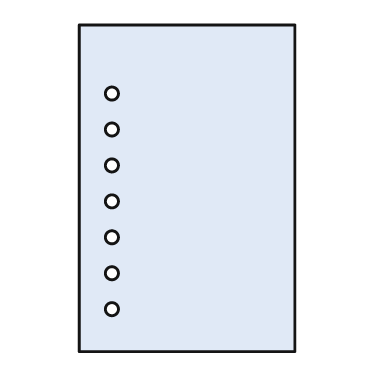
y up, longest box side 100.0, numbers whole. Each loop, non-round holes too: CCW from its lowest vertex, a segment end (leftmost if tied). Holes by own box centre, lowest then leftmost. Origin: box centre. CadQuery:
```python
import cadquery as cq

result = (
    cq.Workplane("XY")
    .moveTo(-33.0, -50.0)
    .lineTo(33.0, -50.0)
    .lineTo(33.0, 50.0)
    .lineTo(-33.0, 50.0)
    .close()
    .moveTo(-23.0, -37.0)
    .circle(2.0)
    .moveTo(-23.0, -26.0)
    .circle(2.0)
    .moveTo(-23.0, -15.0)
    .circle(2.0)
    .moveTo(-23.0, -4.0)
    .circle(2.0)
    .moveTo(-23.0, 7.0)
    .circle(2.0)
    .moveTo(-23.0, 18.0)
    .circle(2.0)
    .moveTo(-23.0, 29.0)
    .circle(2.0)
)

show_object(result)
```